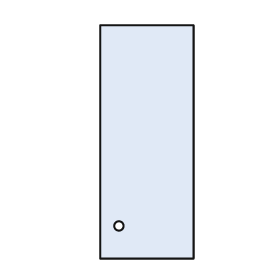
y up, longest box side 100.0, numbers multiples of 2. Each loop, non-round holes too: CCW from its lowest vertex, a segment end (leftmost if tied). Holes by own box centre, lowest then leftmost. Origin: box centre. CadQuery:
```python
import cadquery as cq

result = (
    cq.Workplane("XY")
    .moveTo(-20.0, -50.0)
    .lineTo(20.0, -50.0)
    .lineTo(20.0, 50.0)
    .lineTo(-20.0, 50.0)
    .close()
    .moveTo(-12.0, -36.0)
    .circle(2.0)
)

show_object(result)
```